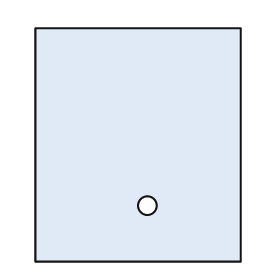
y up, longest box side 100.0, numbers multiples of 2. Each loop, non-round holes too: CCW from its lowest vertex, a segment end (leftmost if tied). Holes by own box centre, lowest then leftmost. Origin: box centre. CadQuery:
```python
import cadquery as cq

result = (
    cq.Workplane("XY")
    .moveTo(-44.0, -50.0)
    .lineTo(44.0, -50.0)
    .lineTo(44.0, 50.0)
    .lineTo(-44.0, 50.0)
    .close()
    .moveTo(4.0, -26.0)
    .circle(4.0)
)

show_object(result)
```